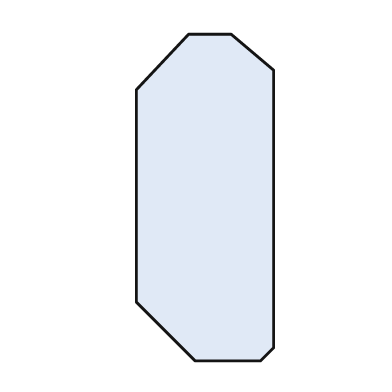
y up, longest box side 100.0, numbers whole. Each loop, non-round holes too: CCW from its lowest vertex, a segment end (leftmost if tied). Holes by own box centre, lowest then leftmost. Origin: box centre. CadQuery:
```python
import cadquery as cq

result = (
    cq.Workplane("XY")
    .moveTo(-3.0, -50.0)
    .lineTo(17.0, -50.0)
    .lineTo(21.0, -46.0)
    .lineTo(21.0, 39.0)
    .lineTo(8.0, 50.0)
    .lineTo(-5.0, 50.0)
    .lineTo(-21.0, 33.0)
    .lineTo(-21.0, -32.0)
    .close()
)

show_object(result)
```